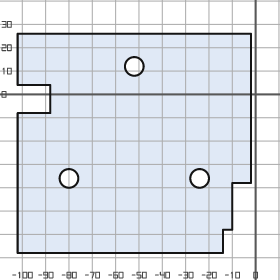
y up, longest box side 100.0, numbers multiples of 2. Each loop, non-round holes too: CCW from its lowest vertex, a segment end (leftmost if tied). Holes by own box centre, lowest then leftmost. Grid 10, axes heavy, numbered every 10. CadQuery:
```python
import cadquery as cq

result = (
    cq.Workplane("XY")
    .moveTo(-102.0, -68.0)
    .lineTo(-14.0, -68.0)
    .lineTo(-14.0, -58.0)
    .lineTo(-10.0, -58.0)
    .lineTo(-10.0, -38.0)
    .lineTo(-2.0, -38.0)
    .lineTo(-2.0, 26.0)
    .lineTo(-102.0, 26.0)
    .lineTo(-102.0, 4.0)
    .lineTo(-88.0, 4.0)
    .lineTo(-88.0, -8.0)
    .lineTo(-102.0, -8.0)
    .close()
    .moveTo(-80.0, -36.0)
    .circle(4.0)
    .moveTo(-24.0, -36.0)
    .circle(4.0)
    .moveTo(-52.0, 12.0)
    .circle(4.0)
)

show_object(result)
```